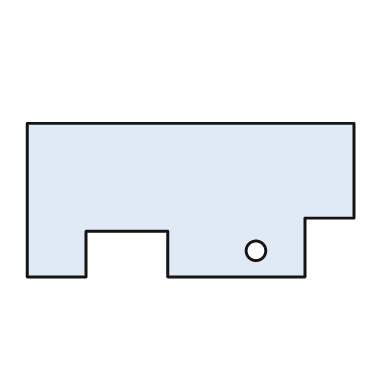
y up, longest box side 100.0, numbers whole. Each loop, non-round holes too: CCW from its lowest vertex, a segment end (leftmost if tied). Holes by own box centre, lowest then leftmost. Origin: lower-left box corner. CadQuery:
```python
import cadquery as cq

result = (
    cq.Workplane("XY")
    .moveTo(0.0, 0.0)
    .lineTo(18.0, 0.0)
    .lineTo(18.0, 14.0)
    .lineTo(43.0, 14.0)
    .lineTo(43.0, 0.0)
    .lineTo(85.0, 0.0)
    .lineTo(85.0, 18.0)
    .lineTo(100.0, 18.0)
    .lineTo(100.0, 47.0)
    .lineTo(0.0, 47.0)
    .close()
    .moveTo(70.0, 8.0)
    .circle(3.0)
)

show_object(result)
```